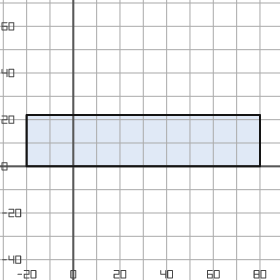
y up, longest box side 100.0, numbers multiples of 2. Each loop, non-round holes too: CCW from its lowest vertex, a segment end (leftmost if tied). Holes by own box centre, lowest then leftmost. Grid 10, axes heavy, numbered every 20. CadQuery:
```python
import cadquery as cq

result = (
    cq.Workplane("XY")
    .moveTo(-20.0, 0.0)
    .lineTo(80.0, 0.0)
    .lineTo(80.0, 22.0)
    .lineTo(-20.0, 22.0)
    .close()
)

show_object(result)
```